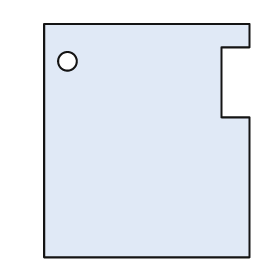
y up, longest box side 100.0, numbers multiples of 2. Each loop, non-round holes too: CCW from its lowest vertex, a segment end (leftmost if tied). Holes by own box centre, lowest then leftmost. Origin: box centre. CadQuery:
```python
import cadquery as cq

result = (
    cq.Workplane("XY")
    .moveTo(-44.0, -50.0)
    .lineTo(44.0, -50.0)
    .lineTo(44.0, 10.0)
    .lineTo(32.0, 10.0)
    .lineTo(32.0, 40.0)
    .lineTo(44.0, 40.0)
    .lineTo(44.0, 50.0)
    .lineTo(-44.0, 50.0)
    .close()
    .moveTo(-34.0, 34.0)
    .circle(4.0)
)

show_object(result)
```